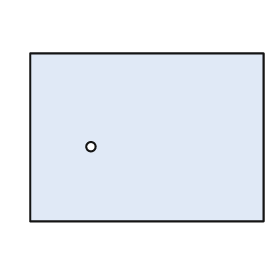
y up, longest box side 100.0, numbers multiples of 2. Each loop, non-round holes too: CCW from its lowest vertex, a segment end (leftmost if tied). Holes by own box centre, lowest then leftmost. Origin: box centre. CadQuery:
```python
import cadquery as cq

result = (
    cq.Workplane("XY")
    .moveTo(-50.0, -36.0)
    .lineTo(50.0, -36.0)
    .lineTo(50.0, 36.0)
    .lineTo(-50.0, 36.0)
    .close()
    .moveTo(-24.0, -4.0)
    .circle(2.0)
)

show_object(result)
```